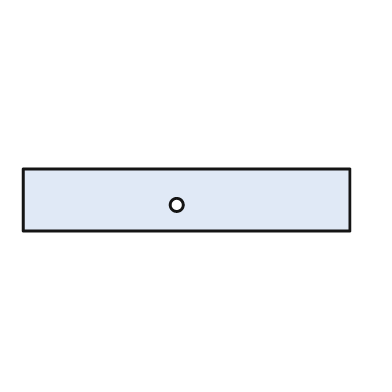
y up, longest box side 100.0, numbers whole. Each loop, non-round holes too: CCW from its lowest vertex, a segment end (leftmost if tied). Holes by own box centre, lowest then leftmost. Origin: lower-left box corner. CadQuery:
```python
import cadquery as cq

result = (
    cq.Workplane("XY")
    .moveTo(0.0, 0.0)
    .lineTo(100.0, 0.0)
    .lineTo(100.0, 19.0)
    .lineTo(0.0, 19.0)
    .close()
    .moveTo(47.0, 8.0)
    .circle(2.0)
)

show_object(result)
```